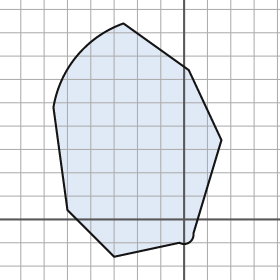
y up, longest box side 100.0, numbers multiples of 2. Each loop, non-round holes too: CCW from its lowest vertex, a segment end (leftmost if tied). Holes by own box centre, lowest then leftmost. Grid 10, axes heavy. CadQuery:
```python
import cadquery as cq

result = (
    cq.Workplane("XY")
    .moveTo(-30.0, -16.0)
    .lineTo(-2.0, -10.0)
    .threePointArc((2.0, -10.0), (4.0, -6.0))
    .lineTo(16.0, 34.0)
    .lineTo(2.0, 64.0)
    .lineTo(-26.0, 84.0)
    .threePointArc((-46.0, 70.0), (-56.0, 48.0))
    .lineTo(-50.0, 4.0)
    .close()
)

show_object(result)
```